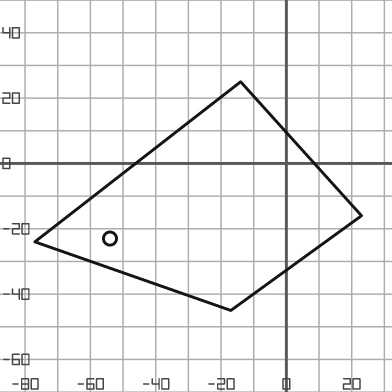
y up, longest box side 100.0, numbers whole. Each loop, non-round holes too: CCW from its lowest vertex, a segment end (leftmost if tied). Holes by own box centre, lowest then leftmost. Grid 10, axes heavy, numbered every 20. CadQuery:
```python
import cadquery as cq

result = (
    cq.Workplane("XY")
    .moveTo(-17.0, -45.0)
    .lineTo(23.0, -16.0)
    .lineTo(-14.0, 25.0)
    .lineTo(-77.0, -24.0)
    .close()
    .moveTo(-54.0, -23.0)
    .circle(2.0)
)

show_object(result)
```